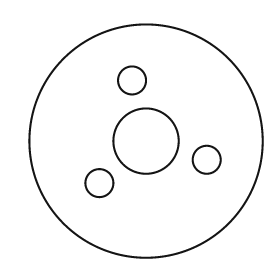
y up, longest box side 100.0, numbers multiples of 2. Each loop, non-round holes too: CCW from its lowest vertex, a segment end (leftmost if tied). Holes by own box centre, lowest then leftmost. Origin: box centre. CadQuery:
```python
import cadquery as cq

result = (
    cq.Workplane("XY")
    .moveTo(0.0, 0.0)
    .circle(50.0)
    .moveTo(-20.0, -18.0)
    .circle(6.0)
    .moveTo(26.0, -8.0)
    .circle(6.0)
    .moveTo(0.0, 0.0)
    .circle(14.0)
    .moveTo(-6.0, 26.0)
    .circle(6.0)
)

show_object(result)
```